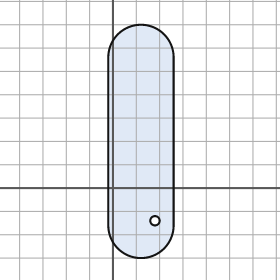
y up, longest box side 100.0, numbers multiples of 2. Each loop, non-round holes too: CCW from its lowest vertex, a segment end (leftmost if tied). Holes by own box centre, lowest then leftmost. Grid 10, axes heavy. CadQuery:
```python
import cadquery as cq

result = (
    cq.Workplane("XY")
    .moveTo(-2.0, -16.0)
    .threePointArc((12.0, -30.0), (26.0, -16.0))
    .lineTo(26.0, 56.0)
    .threePointArc((12.0, 70.0), (-2.0, 56.0))
    .close()
    .moveTo(18.0, -14.0)
    .circle(2.0)
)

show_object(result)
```